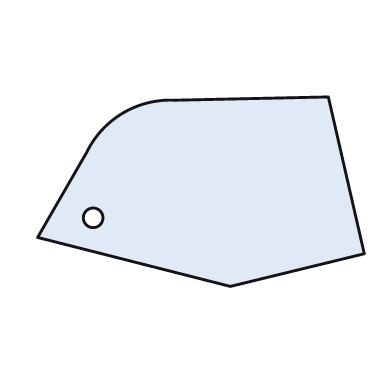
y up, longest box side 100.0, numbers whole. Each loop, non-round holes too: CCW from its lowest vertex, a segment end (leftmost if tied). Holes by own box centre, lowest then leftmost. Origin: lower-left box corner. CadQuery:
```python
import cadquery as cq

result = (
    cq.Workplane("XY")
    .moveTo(59.0, 0.0)
    .lineTo(100.0, 10.0)
    .lineTo(89.0, 58.0)
    .lineTo(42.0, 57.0)
    .threePointArc((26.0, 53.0), (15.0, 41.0))
    .lineTo(0.0, 15.0)
    .close()
    .moveTo(17.0, 21.0)
    .circle(3.0)
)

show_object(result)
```